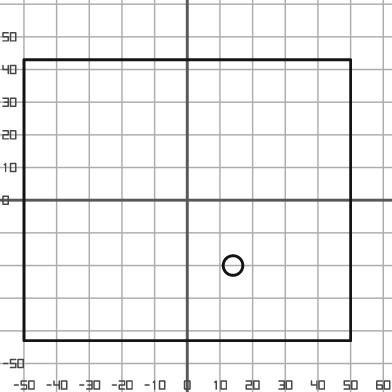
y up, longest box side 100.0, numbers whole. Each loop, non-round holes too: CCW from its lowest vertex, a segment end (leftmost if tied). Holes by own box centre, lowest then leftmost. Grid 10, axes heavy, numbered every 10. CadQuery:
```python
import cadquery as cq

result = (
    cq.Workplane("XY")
    .moveTo(-50.0, -43.0)
    .lineTo(50.0, -43.0)
    .lineTo(50.0, 43.0)
    .lineTo(-50.0, 43.0)
    .close()
    .moveTo(14.0, -20.0)
    .circle(3.0)
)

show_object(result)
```